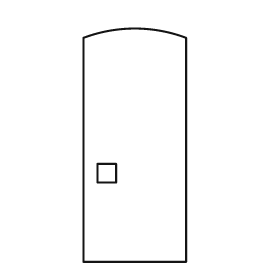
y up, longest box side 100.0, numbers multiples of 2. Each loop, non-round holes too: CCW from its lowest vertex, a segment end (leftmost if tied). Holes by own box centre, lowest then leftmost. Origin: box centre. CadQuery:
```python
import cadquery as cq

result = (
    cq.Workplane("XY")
    .moveTo(-22.0, -50.0)
    .lineTo(22.0, -50.0)
    .lineTo(22.0, 46.0)
    .threePointArc((0.0, 50.0), (-22.0, 46.0))
    .close()
    .moveTo(-16.0, -16.0)
    .lineTo(-8.0, -16.0)
    .lineTo(-8.0, -8.0)
    .lineTo(-16.0, -8.0)
    .close()
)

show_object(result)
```